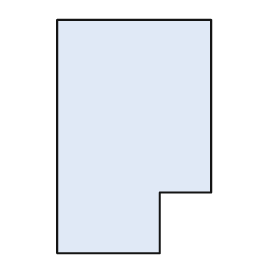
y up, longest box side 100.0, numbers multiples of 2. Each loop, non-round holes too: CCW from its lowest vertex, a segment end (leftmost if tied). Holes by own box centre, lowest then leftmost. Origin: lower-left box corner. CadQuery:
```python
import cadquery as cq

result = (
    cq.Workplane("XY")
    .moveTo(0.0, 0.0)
    .lineTo(44.0, 0.0)
    .lineTo(44.0, 26.0)
    .lineTo(66.0, 26.0)
    .lineTo(66.0, 100.0)
    .lineTo(0.0, 100.0)
    .close()
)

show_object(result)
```